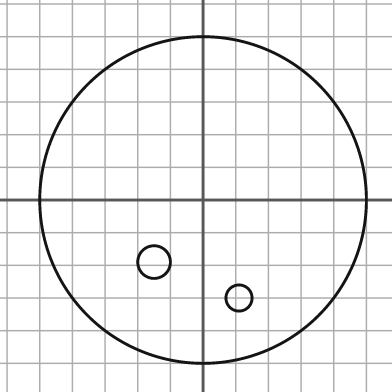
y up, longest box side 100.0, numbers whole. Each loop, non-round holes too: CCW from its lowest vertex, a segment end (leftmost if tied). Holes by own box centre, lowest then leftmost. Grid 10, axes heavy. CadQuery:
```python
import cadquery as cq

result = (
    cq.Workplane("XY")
    .moveTo(0.0, 0.0)
    .circle(50.0)
    .moveTo(11.0, -30.0)
    .circle(4.0)
    .moveTo(-15.0, -19.0)
    .circle(5.0)
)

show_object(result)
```